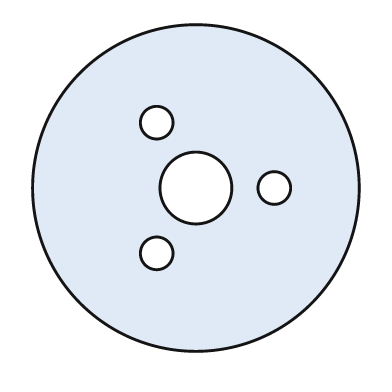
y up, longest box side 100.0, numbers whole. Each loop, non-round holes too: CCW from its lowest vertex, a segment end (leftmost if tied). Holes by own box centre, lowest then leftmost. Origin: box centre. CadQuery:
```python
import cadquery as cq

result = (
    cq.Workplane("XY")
    .moveTo(0.0, 0.0)
    .circle(50.0)
    .moveTo(-12.0, -20.0)
    .circle(5.0)
    .moveTo(0.0, 0.0)
    .circle(11.0)
    .moveTo(24.0, 0.0)
    .circle(5.0)
    .moveTo(-12.0, 20.0)
    .circle(5.0)
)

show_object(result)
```